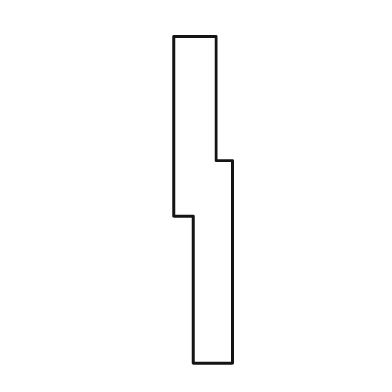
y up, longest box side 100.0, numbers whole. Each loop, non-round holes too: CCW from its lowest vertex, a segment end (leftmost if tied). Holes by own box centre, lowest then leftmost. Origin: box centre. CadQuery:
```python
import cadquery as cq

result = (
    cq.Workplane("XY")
    .moveTo(-3.0, -50.0)
    .lineTo(9.0, -50.0)
    .lineTo(9.0, 12.0)
    .lineTo(4.0, 12.0)
    .lineTo(4.0, 50.0)
    .lineTo(-9.0, 50.0)
    .lineTo(-9.0, -5.0)
    .lineTo(-3.0, -5.0)
    .close()
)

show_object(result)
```